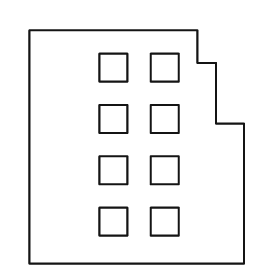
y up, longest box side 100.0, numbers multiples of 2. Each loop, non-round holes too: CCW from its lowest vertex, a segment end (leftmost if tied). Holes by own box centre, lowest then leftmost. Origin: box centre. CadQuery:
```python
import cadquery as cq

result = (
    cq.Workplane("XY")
    .moveTo(-46.0, -50.0)
    .lineTo(46.0, -50.0)
    .lineTo(46.0, 10.0)
    .lineTo(34.0, 10.0)
    .lineTo(34.0, 36.0)
    .lineTo(26.0, 36.0)
    .lineTo(26.0, 50.0)
    .lineTo(-46.0, 50.0)
    .close()
    .moveTo(-16.0, -38.0)
    .lineTo(-4.0, -38.0)
    .lineTo(-4.0, -26.0)
    .lineTo(-16.0, -26.0)
    .close()
    .moveTo(6.0, -38.0)
    .lineTo(18.0, -38.0)
    .lineTo(18.0, -26.0)
    .lineTo(6.0, -26.0)
    .close()
    .moveTo(-16.0, -16.0)
    .lineTo(-4.0, -16.0)
    .lineTo(-4.0, -4.0)
    .lineTo(-16.0, -4.0)
    .close()
    .moveTo(6.0, -16.0)
    .lineTo(18.0, -16.0)
    .lineTo(18.0, -4.0)
    .lineTo(6.0, -4.0)
    .close()
    .moveTo(-16.0, 6.0)
    .lineTo(-4.0, 6.0)
    .lineTo(-4.0, 18.0)
    .lineTo(-16.0, 18.0)
    .close()
    .moveTo(6.0, 6.0)
    .lineTo(18.0, 6.0)
    .lineTo(18.0, 18.0)
    .lineTo(6.0, 18.0)
    .close()
    .moveTo(-16.0, 28.0)
    .lineTo(-4.0, 28.0)
    .lineTo(-4.0, 40.0)
    .lineTo(-16.0, 40.0)
    .close()
    .moveTo(6.0, 28.0)
    .lineTo(18.0, 28.0)
    .lineTo(18.0, 40.0)
    .lineTo(6.0, 40.0)
    .close()
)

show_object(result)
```